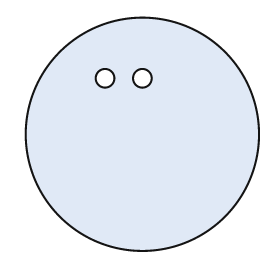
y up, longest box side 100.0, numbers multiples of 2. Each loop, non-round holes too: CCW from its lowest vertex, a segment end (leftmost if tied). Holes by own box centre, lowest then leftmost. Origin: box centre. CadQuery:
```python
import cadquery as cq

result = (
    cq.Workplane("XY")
    .moveTo(0.0, 0.0)
    .circle(50.0)
    .moveTo(-16.0, 24.0)
    .circle(4.0)
    .moveTo(0.0, 24.0)
    .circle(4.0)
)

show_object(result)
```